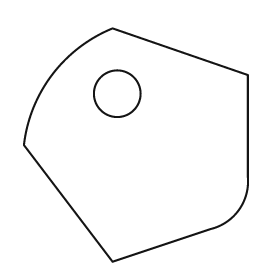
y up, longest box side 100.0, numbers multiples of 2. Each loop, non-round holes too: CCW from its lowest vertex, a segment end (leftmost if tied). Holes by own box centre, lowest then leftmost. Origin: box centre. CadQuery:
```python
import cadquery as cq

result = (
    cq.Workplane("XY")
    .moveTo(-10.0, -50.0)
    .lineTo(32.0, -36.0)
    .threePointArc((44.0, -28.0), (48.0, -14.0))
    .lineTo(48.0, 30.0)
    .lineTo(-10.0, 50.0)
    .threePointArc((-36.0, 30.0), (-48.0, 0.0))
    .close()
    .moveTo(-8.0, 22.0)
    .circle(10.0)
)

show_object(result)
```